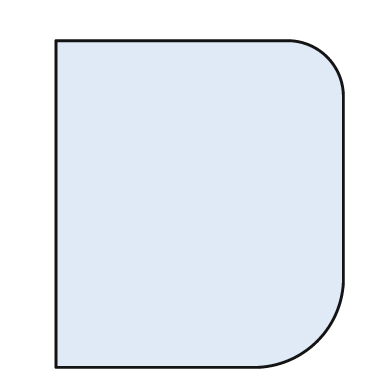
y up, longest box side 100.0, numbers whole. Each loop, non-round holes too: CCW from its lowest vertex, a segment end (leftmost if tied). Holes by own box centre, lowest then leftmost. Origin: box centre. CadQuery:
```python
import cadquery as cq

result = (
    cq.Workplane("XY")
    .moveTo(-44.0, -50.0)
    .lineTo(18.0, -50.0)
    .threePointArc((36.0, -42.0), (44.0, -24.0))
    .lineTo(44.0, 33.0)
    .threePointArc((39.0, 45.0), (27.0, 50.0))
    .lineTo(-44.0, 50.0)
    .close()
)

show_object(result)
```